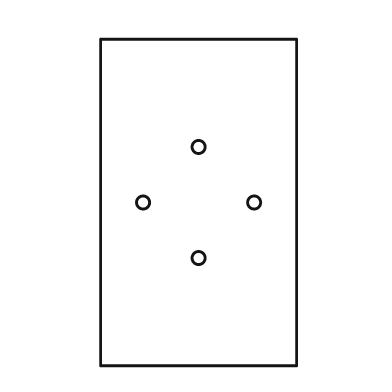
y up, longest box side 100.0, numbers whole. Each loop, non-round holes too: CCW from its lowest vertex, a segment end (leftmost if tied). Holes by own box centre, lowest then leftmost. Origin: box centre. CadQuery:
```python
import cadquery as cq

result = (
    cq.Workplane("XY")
    .moveTo(-30.0, -50.0)
    .lineTo(30.0, -50.0)
    .lineTo(30.0, 50.0)
    .lineTo(-30.0, 50.0)
    .close()
    .moveTo(0.0, -17.0)
    .circle(2.0)
    .moveTo(-17.0, 0.0)
    .circle(2.0)
    .moveTo(17.0, 0.0)
    .circle(2.0)
    .moveTo(0.0, 17.0)
    .circle(2.0)
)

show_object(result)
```